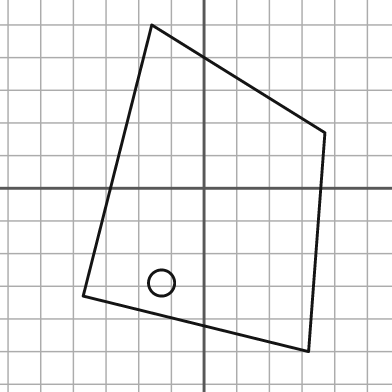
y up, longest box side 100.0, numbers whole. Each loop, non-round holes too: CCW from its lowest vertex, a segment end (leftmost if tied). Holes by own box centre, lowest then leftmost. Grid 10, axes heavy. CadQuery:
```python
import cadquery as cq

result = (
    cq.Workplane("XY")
    .moveTo(32.0, -50.0)
    .lineTo(37.0, 17.0)
    .lineTo(-16.0, 50.0)
    .lineTo(-37.0, -33.0)
    .close()
    .moveTo(-13.0, -29.0)
    .circle(4.0)
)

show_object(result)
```